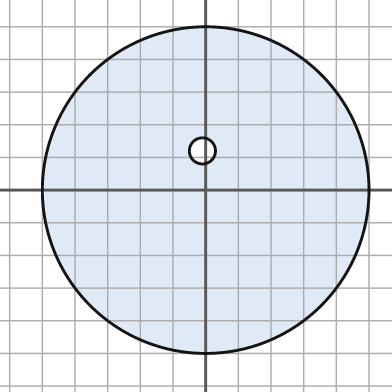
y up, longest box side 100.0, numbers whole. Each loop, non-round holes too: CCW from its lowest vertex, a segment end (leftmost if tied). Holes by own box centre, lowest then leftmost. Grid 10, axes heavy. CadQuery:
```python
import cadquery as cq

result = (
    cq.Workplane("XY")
    .moveTo(0.0, 0.0)
    .circle(50.0)
    .moveTo(-1.0, 12.0)
    .circle(4.0)
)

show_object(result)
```